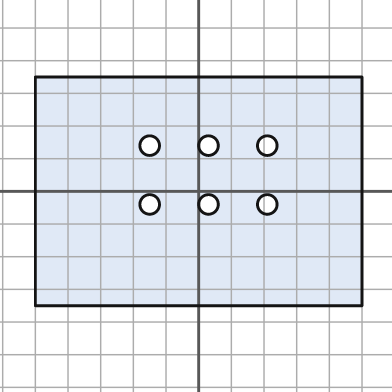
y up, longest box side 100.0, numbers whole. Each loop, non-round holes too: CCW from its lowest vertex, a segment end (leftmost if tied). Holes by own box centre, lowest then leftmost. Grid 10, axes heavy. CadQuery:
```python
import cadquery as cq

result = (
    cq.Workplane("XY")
    .moveTo(-50.0, -35.0)
    .lineTo(50.0, -35.0)
    .lineTo(50.0, 35.0)
    .lineTo(-50.0, 35.0)
    .close()
    .moveTo(-15.0, -4.0)
    .circle(3.0)
    .moveTo(3.0, -4.0)
    .circle(3.0)
    .moveTo(21.0, -4.0)
    .circle(3.0)
    .moveTo(-15.0, 14.0)
    .circle(3.0)
    .moveTo(3.0, 14.0)
    .circle(3.0)
    .moveTo(21.0, 14.0)
    .circle(3.0)
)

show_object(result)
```